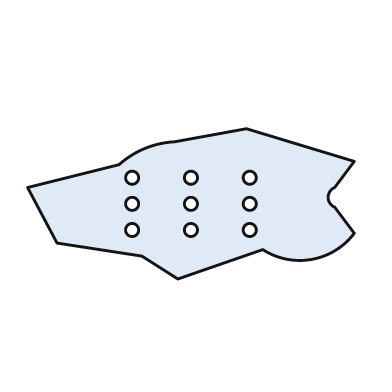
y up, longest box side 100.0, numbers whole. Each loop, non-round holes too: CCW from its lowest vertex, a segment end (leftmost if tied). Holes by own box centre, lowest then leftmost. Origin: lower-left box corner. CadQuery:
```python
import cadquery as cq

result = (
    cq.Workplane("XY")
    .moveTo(46.0, 0.0)
    .lineTo(72.0, 9.0)
    .threePointArc((87.0, 6.0), (100.0, 14.0))
    .lineTo(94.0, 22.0)
    .threePointArc((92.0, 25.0), (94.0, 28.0))
    .lineTo(100.0, 36.0)
    .lineTo(67.0, 46.0)
    .lineTo(45.0, 42.0)
    .threePointArc((36.0, 40.0), (28.0, 35.0))
    .lineTo(0.0, 28.0)
    .lineTo(9.0, 11.0)
    .lineTo(35.0, 7.0)
    .close()
    .moveTo(32.0, 15.0)
    .circle(2.0)
    .moveTo(50.0, 15.0)
    .circle(2.0)
    .moveTo(68.0, 15.0)
    .circle(2.0)
    .moveTo(32.0, 23.0)
    .circle(2.0)
    .moveTo(50.0, 23.0)
    .circle(2.0)
    .moveTo(68.0, 23.0)
    .circle(2.0)
    .moveTo(32.0, 31.0)
    .circle(2.0)
    .moveTo(50.0, 31.0)
    .circle(2.0)
    .moveTo(68.0, 31.0)
    .circle(2.0)
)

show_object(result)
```